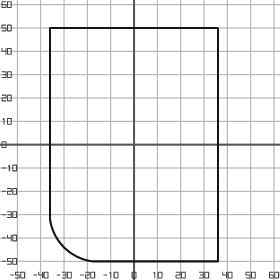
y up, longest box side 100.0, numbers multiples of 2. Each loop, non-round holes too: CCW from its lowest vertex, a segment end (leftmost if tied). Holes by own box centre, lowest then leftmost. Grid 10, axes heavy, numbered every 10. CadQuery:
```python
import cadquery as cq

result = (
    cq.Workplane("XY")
    .moveTo(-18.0, -50.0)
    .lineTo(36.0, -50.0)
    .lineTo(36.0, 50.0)
    .lineTo(-36.0, 50.0)
    .lineTo(-36.0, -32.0)
    .threePointArc((-30.0, -44.0), (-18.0, -50.0))
    .close()
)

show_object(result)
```